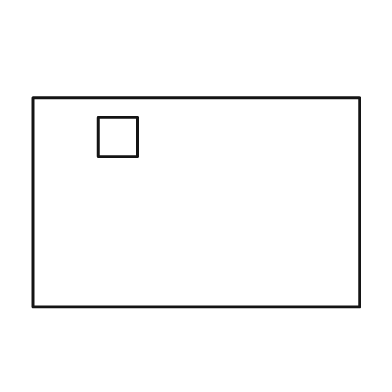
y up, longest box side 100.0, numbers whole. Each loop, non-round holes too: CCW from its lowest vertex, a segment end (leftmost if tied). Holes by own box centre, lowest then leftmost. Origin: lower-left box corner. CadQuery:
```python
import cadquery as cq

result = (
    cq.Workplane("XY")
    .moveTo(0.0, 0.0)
    .lineTo(100.0, 0.0)
    .lineTo(100.0, 64.0)
    .lineTo(0.0, 64.0)
    .close()
    .moveTo(20.0, 46.0)
    .lineTo(32.0, 46.0)
    .lineTo(32.0, 58.0)
    .lineTo(20.0, 58.0)
    .close()
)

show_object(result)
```